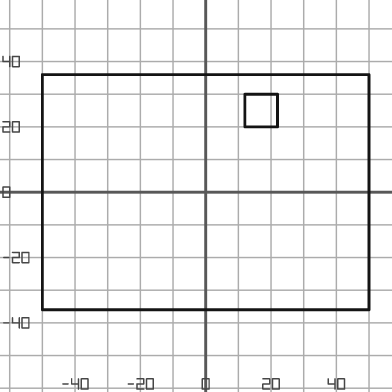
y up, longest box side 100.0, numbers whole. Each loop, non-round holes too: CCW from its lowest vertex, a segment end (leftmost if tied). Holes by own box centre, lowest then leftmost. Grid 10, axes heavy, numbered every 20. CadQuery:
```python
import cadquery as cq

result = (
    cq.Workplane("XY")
    .moveTo(-50.0, -36.0)
    .lineTo(50.0, -36.0)
    .lineTo(50.0, 36.0)
    .lineTo(-50.0, 36.0)
    .close()
    .moveTo(12.0, 20.0)
    .lineTo(22.0, 20.0)
    .lineTo(22.0, 30.0)
    .lineTo(12.0, 30.0)
    .close()
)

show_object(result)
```